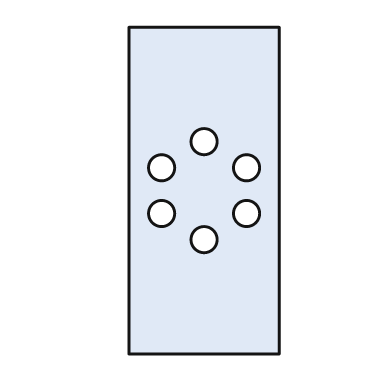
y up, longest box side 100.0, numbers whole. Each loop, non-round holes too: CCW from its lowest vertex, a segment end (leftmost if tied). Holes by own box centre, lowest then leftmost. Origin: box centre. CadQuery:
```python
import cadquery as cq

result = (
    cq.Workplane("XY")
    .moveTo(-23.0, -50.0)
    .lineTo(23.0, -50.0)
    .lineTo(23.0, 50.0)
    .lineTo(-23.0, 50.0)
    .close()
    .moveTo(0.0, -15.0)
    .circle(4.0)
    .moveTo(-13.0, -7.0)
    .circle(4.0)
    .moveTo(13.0, -7.0)
    .circle(4.0)
    .moveTo(-13.0, 7.0)
    .circle(4.0)
    .moveTo(13.0, 7.0)
    .circle(4.0)
    .moveTo(0.0, 15.0)
    .circle(4.0)
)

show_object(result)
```